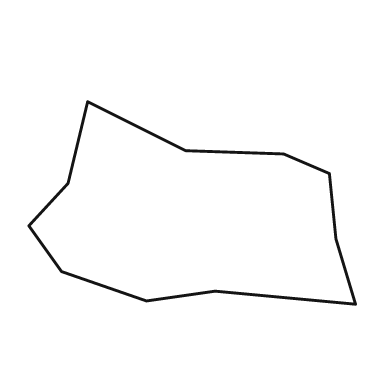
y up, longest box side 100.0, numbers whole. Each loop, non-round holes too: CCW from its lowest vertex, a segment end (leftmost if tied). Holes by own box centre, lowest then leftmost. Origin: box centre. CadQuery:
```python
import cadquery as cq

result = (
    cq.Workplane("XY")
    .moveTo(50.0, -31.0)
    .lineTo(44.0, -11.0)
    .lineTo(42.0, 9.0)
    .lineTo(28.0, 15.0)
    .lineTo(-2.0, 16.0)
    .lineTo(-32.0, 31.0)
    .lineTo(-38.0, 6.0)
    .lineTo(-50.0, -7.0)
    .lineTo(-40.0, -21.0)
    .lineTo(-14.0, -30.0)
    .lineTo(7.0, -27.0)
    .close()
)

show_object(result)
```